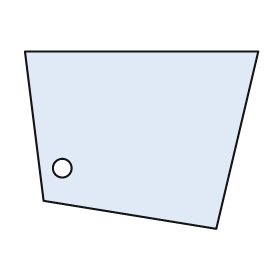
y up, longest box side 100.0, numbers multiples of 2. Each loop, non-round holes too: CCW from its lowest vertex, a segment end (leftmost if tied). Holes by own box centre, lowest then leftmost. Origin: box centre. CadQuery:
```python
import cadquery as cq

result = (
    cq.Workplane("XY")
    .moveTo(32.0, -38.0)
    .lineTo(50.0, 38.0)
    .lineTo(-50.0, 38.0)
    .lineTo(-42.0, -26.0)
    .close()
    .moveTo(-34.0, -12.0)
    .circle(4.0)
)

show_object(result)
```